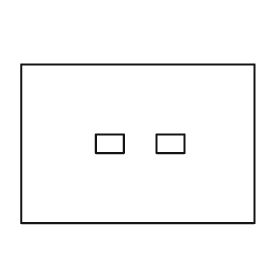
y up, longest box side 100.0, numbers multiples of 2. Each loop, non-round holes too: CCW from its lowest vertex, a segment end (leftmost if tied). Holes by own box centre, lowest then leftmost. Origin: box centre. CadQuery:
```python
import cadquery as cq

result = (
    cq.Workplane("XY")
    .moveTo(-50.0, -34.0)
    .lineTo(50.0, -34.0)
    .lineTo(50.0, 34.0)
    .lineTo(-50.0, 34.0)
    .close()
    .moveTo(-18.0, -4.0)
    .lineTo(-6.0, -4.0)
    .lineTo(-6.0, 4.0)
    .lineTo(-18.0, 4.0)
    .close()
    .moveTo(8.0, -4.0)
    .lineTo(20.0, -4.0)
    .lineTo(20.0, 4.0)
    .lineTo(8.0, 4.0)
    .close()
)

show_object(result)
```